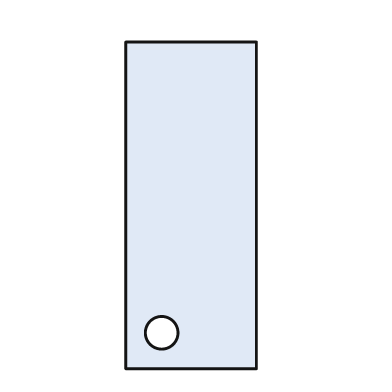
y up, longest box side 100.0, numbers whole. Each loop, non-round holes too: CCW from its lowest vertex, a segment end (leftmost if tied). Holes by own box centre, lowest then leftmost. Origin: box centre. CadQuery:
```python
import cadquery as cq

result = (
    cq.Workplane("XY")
    .moveTo(-20.0, -50.0)
    .lineTo(20.0, -50.0)
    .lineTo(20.0, 50.0)
    .lineTo(-20.0, 50.0)
    .close()
    .moveTo(-9.0, -39.0)
    .circle(5.0)
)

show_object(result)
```